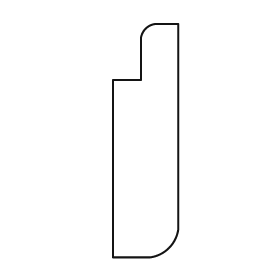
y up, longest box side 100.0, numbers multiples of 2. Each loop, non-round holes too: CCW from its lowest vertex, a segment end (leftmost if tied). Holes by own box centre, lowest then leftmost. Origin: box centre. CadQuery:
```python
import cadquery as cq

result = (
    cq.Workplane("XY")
    .moveTo(-14.0, -50.0)
    .lineTo(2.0, -50.0)
    .threePointArc((10.0, -46.0), (14.0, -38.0))
    .lineTo(14.0, 50.0)
    .lineTo(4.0, 50.0)
    .threePointArc((0.0, 48.0), (-2.0, 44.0))
    .lineTo(-2.0, 26.0)
    .lineTo(-14.0, 26.0)
    .close()
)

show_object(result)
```